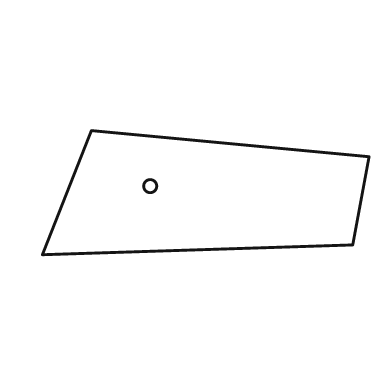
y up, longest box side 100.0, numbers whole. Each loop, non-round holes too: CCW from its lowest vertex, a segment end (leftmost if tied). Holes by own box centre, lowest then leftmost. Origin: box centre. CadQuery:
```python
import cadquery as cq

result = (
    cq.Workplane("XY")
    .moveTo(-50.0, -19.0)
    .lineTo(45.0, -16.0)
    .lineTo(50.0, 11.0)
    .lineTo(-35.0, 19.0)
    .close()
    .moveTo(-17.0, 2.0)
    .circle(2.0)
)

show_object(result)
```